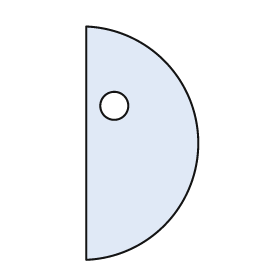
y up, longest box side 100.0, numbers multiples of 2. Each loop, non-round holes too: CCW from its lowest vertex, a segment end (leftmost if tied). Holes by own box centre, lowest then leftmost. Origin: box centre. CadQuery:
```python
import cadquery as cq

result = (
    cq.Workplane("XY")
    .moveTo(-24.0, -50.0)
    .threePointArc((24.0, 0.0), (-24.0, 50.0))
    .close()
    .moveTo(-12.0, 16.0)
    .circle(6.0)
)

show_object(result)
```